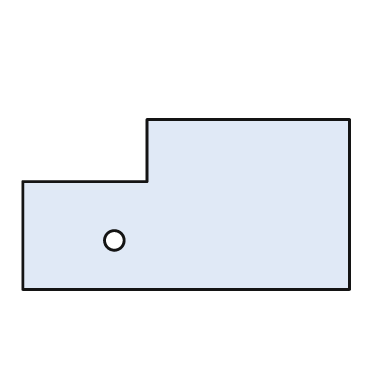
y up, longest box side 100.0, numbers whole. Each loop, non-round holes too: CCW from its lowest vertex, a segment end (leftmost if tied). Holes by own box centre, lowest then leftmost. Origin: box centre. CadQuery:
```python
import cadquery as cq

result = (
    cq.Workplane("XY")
    .moveTo(-50.0, -26.0)
    .lineTo(50.0, -26.0)
    .lineTo(50.0, 26.0)
    .lineTo(-12.0, 26.0)
    .lineTo(-12.0, 7.0)
    .lineTo(-50.0, 7.0)
    .close()
    .moveTo(-22.0, -11.0)
    .circle(3.0)
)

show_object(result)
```